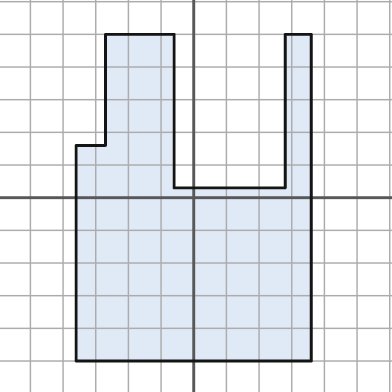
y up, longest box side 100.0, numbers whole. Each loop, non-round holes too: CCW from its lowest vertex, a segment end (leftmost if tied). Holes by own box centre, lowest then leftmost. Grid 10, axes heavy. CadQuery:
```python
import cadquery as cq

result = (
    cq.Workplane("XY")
    .moveTo(-36.0, -50.0)
    .lineTo(36.0, -50.0)
    .lineTo(36.0, 50.0)
    .lineTo(28.0, 50.0)
    .lineTo(28.0, 3.0)
    .lineTo(-6.0, 3.0)
    .lineTo(-6.0, 50.0)
    .lineTo(-27.0, 50.0)
    .lineTo(-27.0, 16.0)
    .lineTo(-36.0, 16.0)
    .close()
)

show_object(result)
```